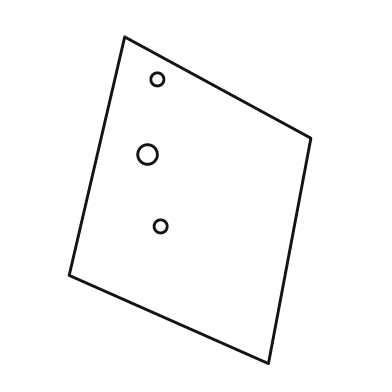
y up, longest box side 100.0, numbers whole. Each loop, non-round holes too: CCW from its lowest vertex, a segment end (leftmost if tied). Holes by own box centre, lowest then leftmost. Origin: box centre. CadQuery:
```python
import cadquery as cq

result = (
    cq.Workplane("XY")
    .moveTo(24.0, -50.0)
    .lineTo(37.0, 19.0)
    .lineTo(-20.0, 50.0)
    .lineTo(-37.0, -23.0)
    .close()
    .moveTo(-9.0, -8.0)
    .circle(2.0)
    .moveTo(-13.0, 14.0)
    .circle(3.0)
    .moveTo(-10.0, 37.0)
    .circle(2.0)
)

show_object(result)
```